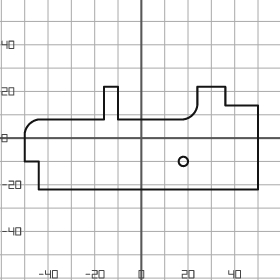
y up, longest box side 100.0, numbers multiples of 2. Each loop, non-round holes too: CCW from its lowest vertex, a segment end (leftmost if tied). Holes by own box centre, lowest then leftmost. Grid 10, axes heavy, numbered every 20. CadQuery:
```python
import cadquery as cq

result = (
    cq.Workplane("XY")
    .moveTo(-44.0, -22.0)
    .lineTo(50.0, -22.0)
    .lineTo(50.0, 14.0)
    .lineTo(36.0, 14.0)
    .lineTo(36.0, 22.0)
    .lineTo(24.0, 22.0)
    .lineTo(24.0, 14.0)
    .threePointArc((22.0, 10.0), (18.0, 8.0))
    .lineTo(-10.0, 8.0)
    .lineTo(-10.0, 22.0)
    .lineTo(-16.0, 22.0)
    .lineTo(-16.0, 8.0)
    .lineTo(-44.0, 8.0)
    .threePointArc((-48.0, 6.0), (-50.0, 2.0))
    .lineTo(-50.0, -10.0)
    .lineTo(-44.0, -10.0)
    .close()
    .moveTo(18.0, -10.0)
    .circle(2.0)
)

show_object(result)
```